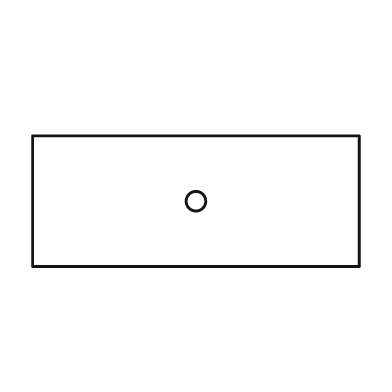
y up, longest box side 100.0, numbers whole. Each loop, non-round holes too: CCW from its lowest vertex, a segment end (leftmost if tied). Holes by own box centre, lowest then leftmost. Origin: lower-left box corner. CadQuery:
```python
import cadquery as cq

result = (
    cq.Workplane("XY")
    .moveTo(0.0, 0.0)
    .lineTo(100.0, 0.0)
    .lineTo(100.0, 40.0)
    .lineTo(0.0, 40.0)
    .close()
    .moveTo(50.0, 20.0)
    .circle(3.0)
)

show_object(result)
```